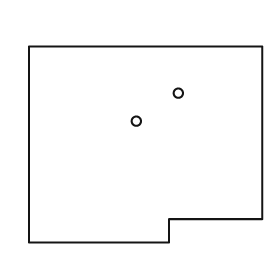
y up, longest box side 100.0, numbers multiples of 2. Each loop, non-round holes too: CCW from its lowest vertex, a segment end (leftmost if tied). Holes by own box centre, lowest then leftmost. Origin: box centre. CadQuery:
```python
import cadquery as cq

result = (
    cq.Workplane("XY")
    .moveTo(-50.0, -42.0)
    .lineTo(10.0, -42.0)
    .lineTo(10.0, -32.0)
    .lineTo(50.0, -32.0)
    .lineTo(50.0, 42.0)
    .lineTo(-50.0, 42.0)
    .close()
    .moveTo(-4.0, 10.0)
    .circle(2.0)
    .moveTo(14.0, 22.0)
    .circle(2.0)
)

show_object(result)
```